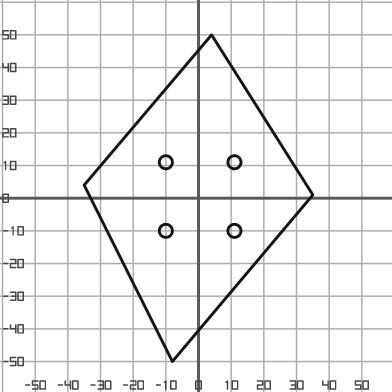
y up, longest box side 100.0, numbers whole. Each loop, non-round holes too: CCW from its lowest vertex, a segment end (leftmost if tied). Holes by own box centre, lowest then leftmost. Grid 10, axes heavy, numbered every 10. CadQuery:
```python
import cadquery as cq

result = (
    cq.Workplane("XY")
    .moveTo(-8.0, -50.0)
    .lineTo(35.0, 1.0)
    .lineTo(4.0, 50.0)
    .lineTo(-35.0, 4.0)
    .close()
    .moveTo(-10.0, -10.0)
    .circle(2.0)
    .moveTo(11.0, -10.0)
    .circle(2.0)
    .moveTo(-10.0, 11.0)
    .circle(2.0)
    .moveTo(11.0, 11.0)
    .circle(2.0)
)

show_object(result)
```